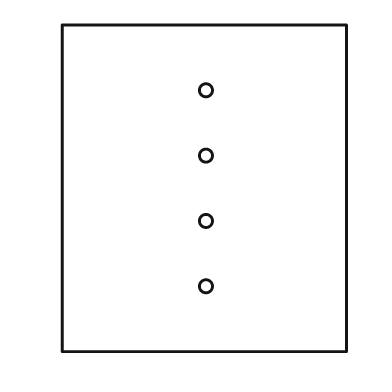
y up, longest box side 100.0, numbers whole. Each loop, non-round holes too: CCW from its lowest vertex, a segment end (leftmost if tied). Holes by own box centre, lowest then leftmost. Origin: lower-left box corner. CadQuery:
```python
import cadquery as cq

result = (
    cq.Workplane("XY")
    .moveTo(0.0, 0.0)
    .lineTo(87.0, 0.0)
    .lineTo(87.0, 100.0)
    .lineTo(0.0, 100.0)
    .close()
    .moveTo(44.0, 20.0)
    .circle(2.0)
    .moveTo(44.0, 40.0)
    .circle(2.0)
    .moveTo(44.0, 60.0)
    .circle(2.0)
    .moveTo(44.0, 80.0)
    .circle(2.0)
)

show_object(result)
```